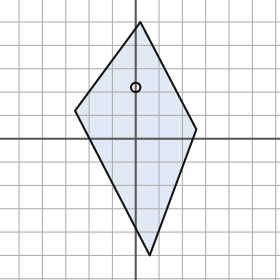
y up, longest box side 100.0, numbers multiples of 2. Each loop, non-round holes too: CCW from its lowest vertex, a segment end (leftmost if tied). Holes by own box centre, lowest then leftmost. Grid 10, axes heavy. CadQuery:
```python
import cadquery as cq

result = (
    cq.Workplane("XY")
    .moveTo(6.0, -50.0)
    .lineTo(26.0, 4.0)
    .lineTo(2.0, 50.0)
    .lineTo(-26.0, 12.0)
    .close()
    .moveTo(0.0, 22.0)
    .circle(2.0)
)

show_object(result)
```